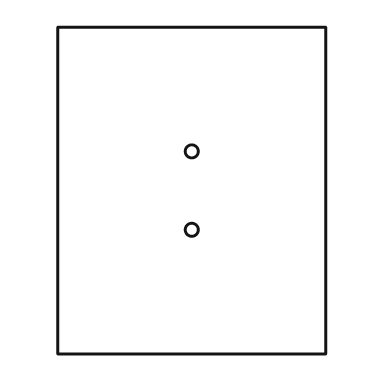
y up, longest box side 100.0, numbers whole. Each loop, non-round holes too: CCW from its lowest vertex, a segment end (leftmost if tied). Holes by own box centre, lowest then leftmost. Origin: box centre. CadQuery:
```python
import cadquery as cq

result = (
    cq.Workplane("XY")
    .moveTo(-41.0, -50.0)
    .lineTo(41.0, -50.0)
    .lineTo(41.0, 50.0)
    .lineTo(-41.0, 50.0)
    .close()
    .moveTo(0.0, -12.0)
    .circle(2.0)
    .moveTo(0.0, 12.0)
    .circle(2.0)
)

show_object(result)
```